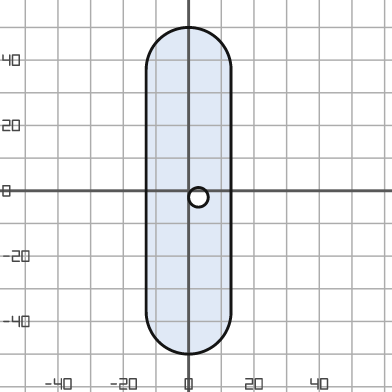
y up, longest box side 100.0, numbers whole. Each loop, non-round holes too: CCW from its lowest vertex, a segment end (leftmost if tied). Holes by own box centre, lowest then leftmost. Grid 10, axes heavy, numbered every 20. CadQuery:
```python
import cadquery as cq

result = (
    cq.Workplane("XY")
    .moveTo(-13.0, -37.0)
    .threePointArc((0.0, -50.0), (13.0, -37.0))
    .lineTo(13.0, 37.0)
    .threePointArc((0.0, 50.0), (-13.0, 37.0))
    .close()
    .moveTo(3.0, -2.0)
    .circle(3.0)
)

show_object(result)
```